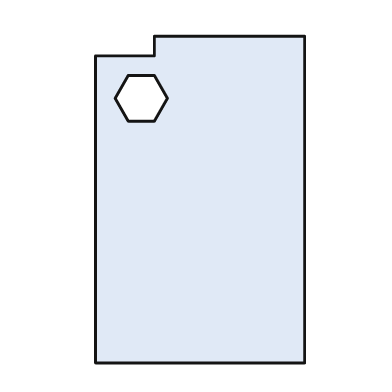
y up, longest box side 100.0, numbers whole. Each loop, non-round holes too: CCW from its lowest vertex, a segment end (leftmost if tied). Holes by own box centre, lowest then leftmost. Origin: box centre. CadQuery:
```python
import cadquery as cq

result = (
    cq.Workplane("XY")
    .moveTo(-32.0, -50.0)
    .lineTo(32.0, -50.0)
    .lineTo(32.0, 50.0)
    .lineTo(-14.0, 50.0)
    .lineTo(-14.0, 44.0)
    .lineTo(-32.0, 44.0)
    .close()
    .moveTo(-22.0, 24.0)
    .lineTo(-14.0, 24.0)
    .lineTo(-10.0, 31.0)
    .lineTo(-14.0, 38.0)
    .lineTo(-22.0, 38.0)
    .lineTo(-26.0, 31.0)
    .close()
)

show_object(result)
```